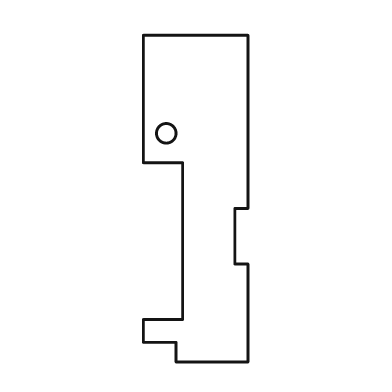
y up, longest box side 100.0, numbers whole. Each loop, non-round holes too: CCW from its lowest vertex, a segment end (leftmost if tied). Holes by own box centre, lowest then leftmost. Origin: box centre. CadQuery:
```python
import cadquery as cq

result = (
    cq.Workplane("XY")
    .moveTo(-6.0, -50.0)
    .lineTo(16.0, -50.0)
    .lineTo(16.0, -20.0)
    .lineTo(12.0, -20.0)
    .lineTo(12.0, -3.0)
    .lineTo(16.0, -3.0)
    .lineTo(16.0, 50.0)
    .lineTo(-16.0, 50.0)
    .lineTo(-16.0, 11.0)
    .lineTo(-4.0, 11.0)
    .lineTo(-4.0, -37.0)
    .lineTo(-16.0, -37.0)
    .lineTo(-16.0, -44.0)
    .lineTo(-6.0, -44.0)
    .close()
    .moveTo(-9.0, 20.0)
    .circle(3.0)
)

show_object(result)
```